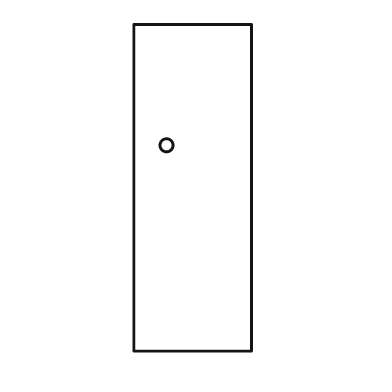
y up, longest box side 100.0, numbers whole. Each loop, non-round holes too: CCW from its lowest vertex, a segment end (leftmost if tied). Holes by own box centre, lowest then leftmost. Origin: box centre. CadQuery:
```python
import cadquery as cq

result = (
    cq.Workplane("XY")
    .moveTo(-18.0, -50.0)
    .lineTo(18.0, -50.0)
    .lineTo(18.0, 50.0)
    .lineTo(-18.0, 50.0)
    .close()
    .moveTo(-8.0, 13.0)
    .circle(2.0)
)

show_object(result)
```